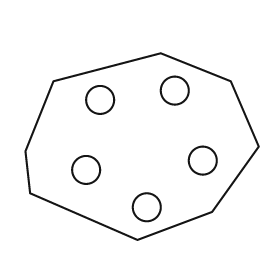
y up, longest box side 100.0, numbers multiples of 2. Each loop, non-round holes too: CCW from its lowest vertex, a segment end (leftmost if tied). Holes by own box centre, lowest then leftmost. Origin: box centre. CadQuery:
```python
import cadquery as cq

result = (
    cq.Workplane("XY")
    .moveTo(-2.0, -40.0)
    .lineTo(30.0, -28.0)
    .lineTo(50.0, 0.0)
    .lineTo(38.0, 28.0)
    .lineTo(8.0, 40.0)
    .lineTo(-38.0, 28.0)
    .lineTo(-50.0, -2.0)
    .lineTo(-48.0, -20.0)
    .close()
    .moveTo(2.0, -26.0)
    .circle(6.0)
    .moveTo(-24.0, -10.0)
    .circle(6.0)
    .moveTo(26.0, -6.0)
    .circle(6.0)
    .moveTo(-18.0, 20.0)
    .circle(6.0)
    .moveTo(14.0, 24.0)
    .circle(6.0)
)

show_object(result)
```